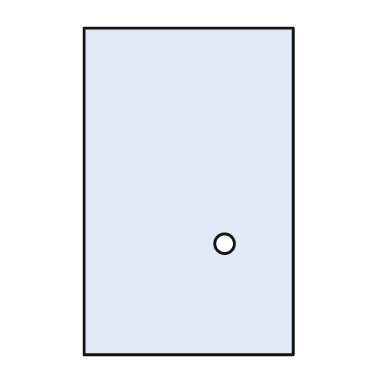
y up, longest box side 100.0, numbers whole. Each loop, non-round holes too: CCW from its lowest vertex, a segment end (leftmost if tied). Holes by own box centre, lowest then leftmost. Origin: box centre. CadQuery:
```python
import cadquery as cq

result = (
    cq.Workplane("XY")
    .moveTo(-32.0, -50.0)
    .lineTo(32.0, -50.0)
    .lineTo(32.0, 50.0)
    .lineTo(-32.0, 50.0)
    .close()
    .moveTo(11.0, -16.0)
    .circle(3.0)
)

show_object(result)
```